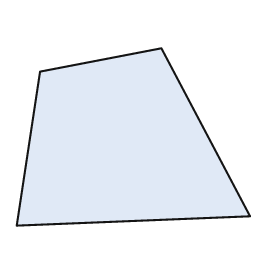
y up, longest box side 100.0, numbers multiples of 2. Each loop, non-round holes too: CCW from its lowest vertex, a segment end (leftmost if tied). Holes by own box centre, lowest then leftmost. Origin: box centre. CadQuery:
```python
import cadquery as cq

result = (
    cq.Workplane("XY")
    .moveTo(-50.0, -38.0)
    .lineTo(50.0, -34.0)
    .lineTo(12.0, 38.0)
    .lineTo(-40.0, 28.0)
    .close()
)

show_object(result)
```